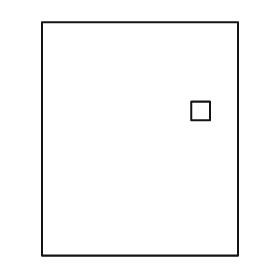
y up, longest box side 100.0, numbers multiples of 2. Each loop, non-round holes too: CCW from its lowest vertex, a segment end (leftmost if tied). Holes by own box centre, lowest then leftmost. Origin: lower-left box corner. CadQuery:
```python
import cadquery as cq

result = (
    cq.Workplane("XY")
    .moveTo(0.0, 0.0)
    .lineTo(84.0, 0.0)
    .lineTo(84.0, 100.0)
    .lineTo(0.0, 100.0)
    .close()
    .moveTo(64.0, 58.0)
    .lineTo(72.0, 58.0)
    .lineTo(72.0, 66.0)
    .lineTo(64.0, 66.0)
    .close()
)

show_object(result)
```